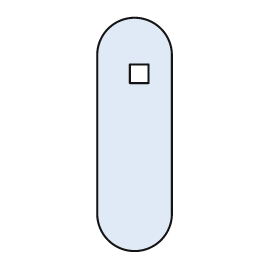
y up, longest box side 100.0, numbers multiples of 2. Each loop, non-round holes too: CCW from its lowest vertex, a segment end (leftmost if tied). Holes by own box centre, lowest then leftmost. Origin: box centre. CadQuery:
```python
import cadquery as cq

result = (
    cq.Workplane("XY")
    .moveTo(-16.0, -34.0)
    .threePointArc((0.0, -50.0), (16.0, -34.0))
    .lineTo(16.0, 34.0)
    .threePointArc((0.0, 50.0), (-16.0, 34.0))
    .close()
    .moveTo(-2.0, 22.0)
    .lineTo(6.0, 22.0)
    .lineTo(6.0, 30.0)
    .lineTo(-2.0, 30.0)
    .close()
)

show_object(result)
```